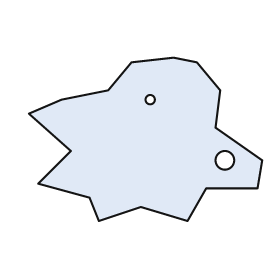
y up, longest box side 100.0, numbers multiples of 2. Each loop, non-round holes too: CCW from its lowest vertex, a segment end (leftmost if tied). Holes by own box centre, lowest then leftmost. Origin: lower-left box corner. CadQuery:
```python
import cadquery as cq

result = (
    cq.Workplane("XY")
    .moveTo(30.0, 0.0)
    .lineTo(48.0, 6.0)
    .lineTo(68.0, 0.0)
    .lineTo(76.0, 14.0)
    .lineTo(98.0, 14.0)
    .lineTo(100.0, 26.0)
    .lineTo(80.0, 40.0)
    .lineTo(82.0, 56.0)
    .lineTo(72.0, 68.0)
    .lineTo(62.0, 70.0)
    .lineTo(44.0, 68.0)
    .lineTo(34.0, 56.0)
    .lineTo(14.0, 52.0)
    .lineTo(0.0, 46.0)
    .lineTo(18.0, 30.0)
    .lineTo(4.0, 16.0)
    .lineTo(26.0, 10.0)
    .close()
    .moveTo(84.0, 26.0)
    .circle(4.0)
    .moveTo(52.0, 52.0)
    .circle(2.0)
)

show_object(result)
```